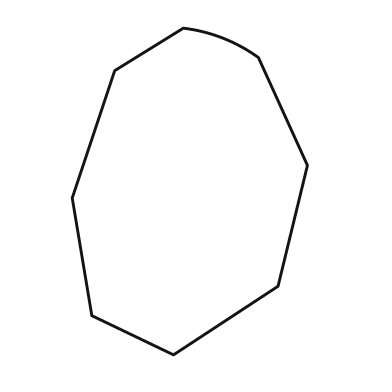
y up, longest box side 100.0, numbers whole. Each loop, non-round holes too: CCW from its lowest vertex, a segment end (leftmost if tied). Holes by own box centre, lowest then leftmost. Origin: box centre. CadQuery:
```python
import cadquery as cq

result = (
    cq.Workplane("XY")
    .moveTo(-5.0, -50.0)
    .lineTo(27.0, -29.0)
    .lineTo(36.0, 8.0)
    .lineTo(21.0, 41.0)
    .threePointArc((10.0, 47.0), (-2.0, 50.0))
    .lineTo(-23.0, 37.0)
    .lineTo(-36.0, -2.0)
    .lineTo(-30.0, -38.0)
    .close()
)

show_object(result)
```